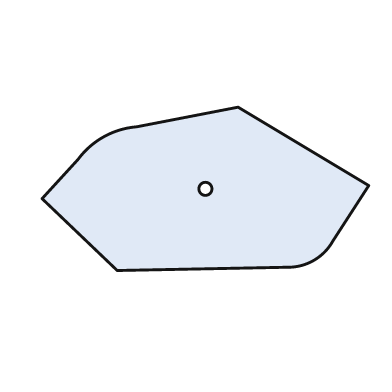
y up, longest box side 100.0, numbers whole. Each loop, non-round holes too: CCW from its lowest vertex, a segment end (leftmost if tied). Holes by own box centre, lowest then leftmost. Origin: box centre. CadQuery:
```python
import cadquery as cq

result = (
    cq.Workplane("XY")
    .moveTo(-27.0, -25.0)
    .lineTo(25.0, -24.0)
    .threePointArc((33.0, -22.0), (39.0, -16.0))
    .lineTo(50.0, 1.0)
    .lineTo(10.0, 25.0)
    .lineTo(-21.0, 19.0)
    .threePointArc((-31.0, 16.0), (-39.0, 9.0))
    .lineTo(-50.0, -3.0)
    .close()
    .moveTo(0.0, 0.0)
    .circle(2.0)
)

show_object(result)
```